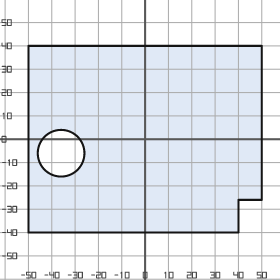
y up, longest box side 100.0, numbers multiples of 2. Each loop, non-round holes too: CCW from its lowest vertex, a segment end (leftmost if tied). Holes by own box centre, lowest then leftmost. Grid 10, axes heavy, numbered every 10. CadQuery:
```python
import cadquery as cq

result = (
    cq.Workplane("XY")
    .moveTo(-50.0, -40.0)
    .lineTo(40.0, -40.0)
    .lineTo(40.0, -26.0)
    .lineTo(50.0, -26.0)
    .lineTo(50.0, 40.0)
    .lineTo(-50.0, 40.0)
    .close()
    .moveTo(-36.0, -6.0)
    .circle(10.0)
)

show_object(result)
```